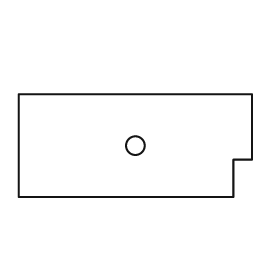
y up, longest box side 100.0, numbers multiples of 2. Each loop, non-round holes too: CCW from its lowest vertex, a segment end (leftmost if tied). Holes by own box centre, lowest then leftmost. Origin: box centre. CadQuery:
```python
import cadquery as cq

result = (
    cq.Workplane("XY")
    .moveTo(-50.0, -22.0)
    .lineTo(42.0, -22.0)
    .lineTo(42.0, -6.0)
    .lineTo(50.0, -6.0)
    .lineTo(50.0, 22.0)
    .lineTo(-50.0, 22.0)
    .close()
    .moveTo(0.0, 0.0)
    .circle(4.0)
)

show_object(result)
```